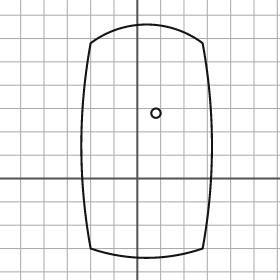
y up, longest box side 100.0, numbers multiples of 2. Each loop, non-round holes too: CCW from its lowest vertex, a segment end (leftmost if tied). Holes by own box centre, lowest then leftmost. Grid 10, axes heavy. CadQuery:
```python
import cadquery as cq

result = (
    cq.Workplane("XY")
    .moveTo(-20.0, -30.0)
    .threePointArc((4.0, -34.0), (28.0, -30.0))
    .threePointArc((32.0, 14.0), (28.0, 58.0))
    .threePointArc((4.0, 66.0), (-20.0, 58.0))
    .threePointArc((-24.0, 14.0), (-20.0, -30.0))
    .close()
    .moveTo(8.0, 28.0)
    .circle(2.0)
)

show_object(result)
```